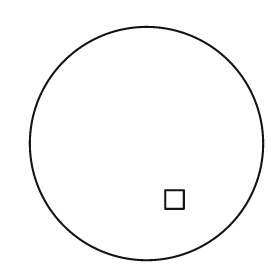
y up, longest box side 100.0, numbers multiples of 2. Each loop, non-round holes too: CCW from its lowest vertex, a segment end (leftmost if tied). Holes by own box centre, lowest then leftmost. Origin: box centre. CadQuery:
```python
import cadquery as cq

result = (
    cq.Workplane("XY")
    .moveTo(0.0, 0.0)
    .circle(50.0)
    .moveTo(8.0, -28.0)
    .lineTo(16.0, -28.0)
    .lineTo(16.0, -20.0)
    .lineTo(8.0, -20.0)
    .close()
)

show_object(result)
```